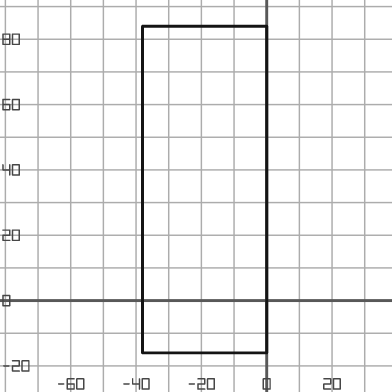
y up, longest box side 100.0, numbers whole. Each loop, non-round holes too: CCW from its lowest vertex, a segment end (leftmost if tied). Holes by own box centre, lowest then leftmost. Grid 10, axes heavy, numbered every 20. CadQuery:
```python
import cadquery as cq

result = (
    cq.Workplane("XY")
    .moveTo(-38.0, -16.0)
    .lineTo(0.0, -16.0)
    .lineTo(0.0, 84.0)
    .lineTo(-38.0, 84.0)
    .close()
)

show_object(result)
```